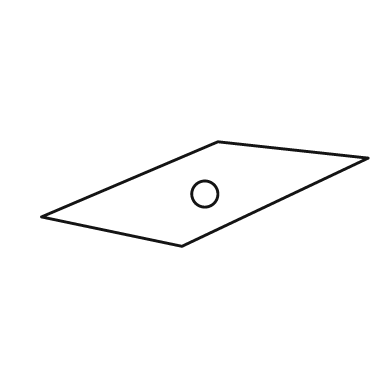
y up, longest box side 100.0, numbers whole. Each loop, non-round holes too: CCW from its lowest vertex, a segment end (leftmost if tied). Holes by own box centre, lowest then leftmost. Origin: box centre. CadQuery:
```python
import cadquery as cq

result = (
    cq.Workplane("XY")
    .moveTo(-7.0, -16.0)
    .lineTo(50.0, 11.0)
    .lineTo(4.0, 16.0)
    .lineTo(-50.0, -7.0)
    .close()
    .moveTo(0.0, 0.0)
    .circle(4.0)
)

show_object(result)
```